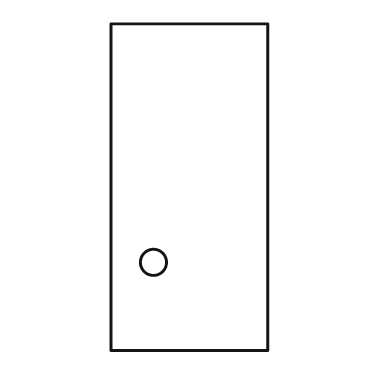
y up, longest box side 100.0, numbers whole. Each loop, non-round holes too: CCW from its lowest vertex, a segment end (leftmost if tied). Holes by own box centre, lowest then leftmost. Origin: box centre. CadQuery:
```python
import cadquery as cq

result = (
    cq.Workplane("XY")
    .moveTo(-24.0, -50.0)
    .lineTo(24.0, -50.0)
    .lineTo(24.0, 50.0)
    .lineTo(-24.0, 50.0)
    .close()
    .moveTo(-11.0, -23.0)
    .circle(4.0)
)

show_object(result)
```